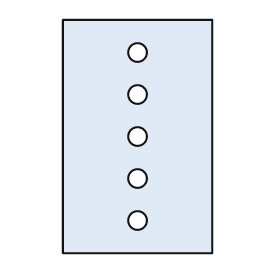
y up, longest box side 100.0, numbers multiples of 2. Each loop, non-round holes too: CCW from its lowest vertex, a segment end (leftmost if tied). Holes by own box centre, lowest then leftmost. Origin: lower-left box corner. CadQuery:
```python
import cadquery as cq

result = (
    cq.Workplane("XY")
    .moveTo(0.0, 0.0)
    .lineTo(64.0, 0.0)
    .lineTo(64.0, 100.0)
    .lineTo(0.0, 100.0)
    .close()
    .moveTo(32.0, 14.0)
    .circle(4.0)
    .moveTo(32.0, 32.0)
    .circle(4.0)
    .moveTo(32.0, 50.0)
    .circle(4.0)
    .moveTo(32.0, 68.0)
    .circle(4.0)
    .moveTo(32.0, 86.0)
    .circle(4.0)
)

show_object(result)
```